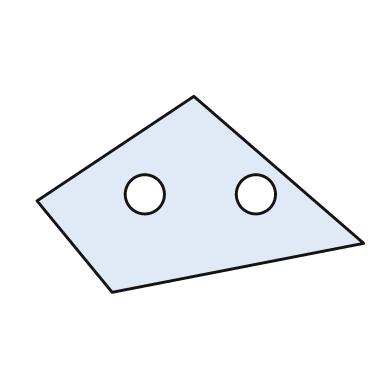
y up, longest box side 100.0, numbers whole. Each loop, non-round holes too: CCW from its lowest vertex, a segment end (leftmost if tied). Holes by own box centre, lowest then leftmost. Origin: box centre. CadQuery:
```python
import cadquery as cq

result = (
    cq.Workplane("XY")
    .moveTo(-27.0, -30.0)
    .lineTo(50.0, -15.0)
    .lineTo(-2.0, 30.0)
    .lineTo(-50.0, -2.0)
    .close()
    .moveTo(-17.0, 0.0)
    .circle(6.0)
    .moveTo(17.0, 0.0)
    .circle(6.0)
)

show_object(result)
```